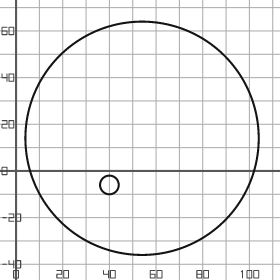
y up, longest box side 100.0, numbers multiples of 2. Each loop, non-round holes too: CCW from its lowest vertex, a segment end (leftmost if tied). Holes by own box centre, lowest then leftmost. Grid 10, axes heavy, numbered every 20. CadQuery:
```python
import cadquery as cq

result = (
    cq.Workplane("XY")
    .moveTo(54.0, 14.0)
    .circle(50.0)
    .moveTo(40.0, -6.0)
    .circle(4.0)
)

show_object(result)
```